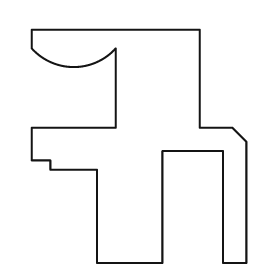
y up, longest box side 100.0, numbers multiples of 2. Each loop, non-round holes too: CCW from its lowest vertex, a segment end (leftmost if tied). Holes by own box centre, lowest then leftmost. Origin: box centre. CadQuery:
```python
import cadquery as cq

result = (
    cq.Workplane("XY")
    .moveTo(-18.0, -50.0)
    .lineTo(10.0, -50.0)
    .lineTo(10.0, -2.0)
    .lineTo(36.0, -2.0)
    .lineTo(36.0, -50.0)
    .lineTo(46.0, -50.0)
    .lineTo(46.0, 2.0)
    .lineTo(40.0, 8.0)
    .lineTo(26.0, 8.0)
    .lineTo(26.0, 50.0)
    .lineTo(-46.0, 50.0)
    .lineTo(-46.0, 42.0)
    .threePointArc((-28.0, 34.0), (-10.0, 42.0))
    .lineTo(-10.0, 8.0)
    .lineTo(-46.0, 8.0)
    .lineTo(-46.0, -6.0)
    .lineTo(-38.0, -6.0)
    .lineTo(-38.0, -10.0)
    .lineTo(-18.0, -10.0)
    .close()
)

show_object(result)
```